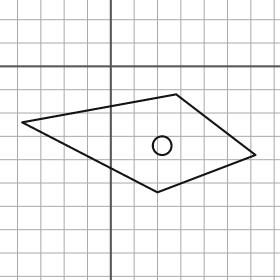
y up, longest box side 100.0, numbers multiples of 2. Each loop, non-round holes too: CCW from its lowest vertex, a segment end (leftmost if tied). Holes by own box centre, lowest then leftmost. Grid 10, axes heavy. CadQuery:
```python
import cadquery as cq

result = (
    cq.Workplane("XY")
    .moveTo(20.0, -54.0)
    .lineTo(62.0, -38.0)
    .lineTo(28.0, -12.0)
    .lineTo(-38.0, -24.0)
    .close()
    .moveTo(22.0, -34.0)
    .circle(4.0)
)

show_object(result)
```